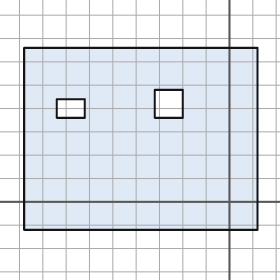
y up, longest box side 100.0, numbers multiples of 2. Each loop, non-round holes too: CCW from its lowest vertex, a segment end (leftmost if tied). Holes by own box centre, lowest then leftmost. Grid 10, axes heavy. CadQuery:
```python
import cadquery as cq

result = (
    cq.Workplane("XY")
    .moveTo(-88.0, -12.0)
    .lineTo(12.0, -12.0)
    .lineTo(12.0, 66.0)
    .lineTo(-88.0, 66.0)
    .close()
    .moveTo(-74.0, 36.0)
    .lineTo(-62.0, 36.0)
    .lineTo(-62.0, 44.0)
    .lineTo(-74.0, 44.0)
    .close()
    .moveTo(-32.0, 36.0)
    .lineTo(-20.0, 36.0)
    .lineTo(-20.0, 48.0)
    .lineTo(-32.0, 48.0)
    .close()
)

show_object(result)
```